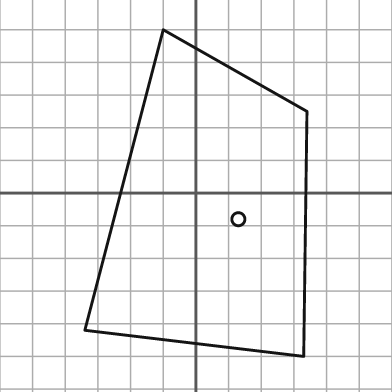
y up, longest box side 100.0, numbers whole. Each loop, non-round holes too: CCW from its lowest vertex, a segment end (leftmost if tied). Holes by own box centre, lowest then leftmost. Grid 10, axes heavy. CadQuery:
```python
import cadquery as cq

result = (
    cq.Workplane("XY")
    .moveTo(33.0, -50.0)
    .lineTo(34.0, 25.0)
    .lineTo(-10.0, 50.0)
    .lineTo(-34.0, -42.0)
    .close()
    .moveTo(13.0, -8.0)
    .circle(2.0)
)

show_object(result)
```